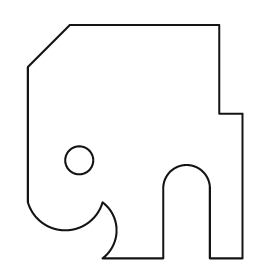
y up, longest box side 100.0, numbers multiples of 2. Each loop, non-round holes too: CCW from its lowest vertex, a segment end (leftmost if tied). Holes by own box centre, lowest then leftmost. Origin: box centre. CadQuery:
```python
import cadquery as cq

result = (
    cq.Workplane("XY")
    .moveTo(-14.0, -50.0)
    .lineTo(12.0, -50.0)
    .lineTo(12.0, -20.0)
    .threePointArc((22.0, -10.0), (32.0, -20.0))
    .lineTo(32.0, -50.0)
    .lineTo(46.0, -50.0)
    .lineTo(46.0, 12.0)
    .lineTo(36.0, 12.0)
    .lineTo(36.0, 50.0)
    .lineTo(-28.0, 50.0)
    .lineTo(-46.0, 32.0)
    .lineTo(-46.0, -26.0)
    .threePointArc((-30.0, -38.0), (-14.0, -26.0))
    .threePointArc((-8.0, -38.0), (-14.0, -50.0))
    .close()
    .moveTo(-24.0, -8.0)
    .circle(6.0)
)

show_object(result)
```